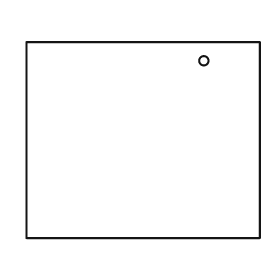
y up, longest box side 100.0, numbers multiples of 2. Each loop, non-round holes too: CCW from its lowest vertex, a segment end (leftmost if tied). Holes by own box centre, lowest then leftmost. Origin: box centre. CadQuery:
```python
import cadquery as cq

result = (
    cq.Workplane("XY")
    .moveTo(-50.0, -42.0)
    .lineTo(50.0, -42.0)
    .lineTo(50.0, 42.0)
    .lineTo(-50.0, 42.0)
    .close()
    .moveTo(26.0, 34.0)
    .circle(2.0)
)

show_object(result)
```